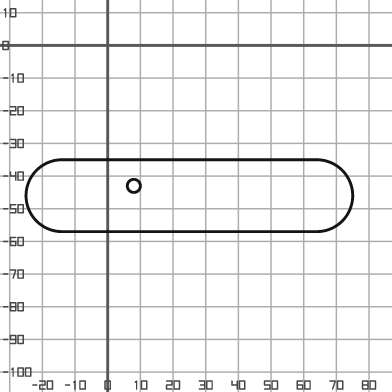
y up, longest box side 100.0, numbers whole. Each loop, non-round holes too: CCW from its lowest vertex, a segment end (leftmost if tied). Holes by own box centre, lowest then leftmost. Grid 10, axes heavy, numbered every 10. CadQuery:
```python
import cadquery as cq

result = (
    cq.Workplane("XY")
    .moveTo(-14.0, -57.0)
    .lineTo(64.0, -57.0)
    .threePointArc((75.0, -46.0), (64.0, -35.0))
    .lineTo(-14.0, -35.0)
    .threePointArc((-25.0, -46.0), (-14.0, -57.0))
    .close()
    .moveTo(8.0, -43.0)
    .circle(2.0)
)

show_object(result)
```